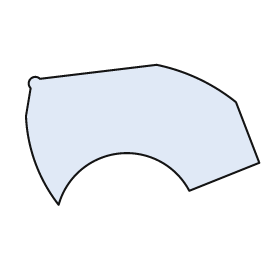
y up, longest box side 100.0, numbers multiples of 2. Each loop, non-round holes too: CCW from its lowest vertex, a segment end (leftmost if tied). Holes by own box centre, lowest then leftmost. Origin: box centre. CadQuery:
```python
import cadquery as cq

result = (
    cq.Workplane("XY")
    .moveTo(-36.0, -30.0)
    .threePointArc((-10.0, -8.0), (20.0, -24.0))
    .lineTo(50.0, -12.0)
    .lineTo(40.0, 14.0)
    .threePointArc((24.0, 24.0), (6.0, 30.0))
    .lineTo(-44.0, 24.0)
    .threePointArc((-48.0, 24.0), (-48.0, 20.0))
    .lineTo(-50.0, 8.0)
    .threePointArc((-46.0, -12.0), (-36.0, -30.0))
    .close()
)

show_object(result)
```